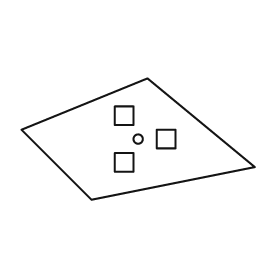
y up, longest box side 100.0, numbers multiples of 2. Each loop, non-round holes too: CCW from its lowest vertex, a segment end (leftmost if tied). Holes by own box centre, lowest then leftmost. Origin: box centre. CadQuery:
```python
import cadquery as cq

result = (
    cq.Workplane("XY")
    .moveTo(-20.0, -26.0)
    .lineTo(50.0, -12.0)
    .lineTo(4.0, 26.0)
    .lineTo(-50.0, 4.0)
    .close()
    .moveTo(-10.0, -14.0)
    .lineTo(-2.0, -14.0)
    .lineTo(-2.0, -6.0)
    .lineTo(-10.0, -6.0)
    .close()
    .moveTo(0.0, 0.0)
    .circle(2.0)
    .moveTo(8.0, -4.0)
    .lineTo(16.0, -4.0)
    .lineTo(16.0, 4.0)
    .lineTo(8.0, 4.0)
    .close()
    .moveTo(-10.0, 6.0)
    .lineTo(-2.0, 6.0)
    .lineTo(-2.0, 14.0)
    .lineTo(-10.0, 14.0)
    .close()
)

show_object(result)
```